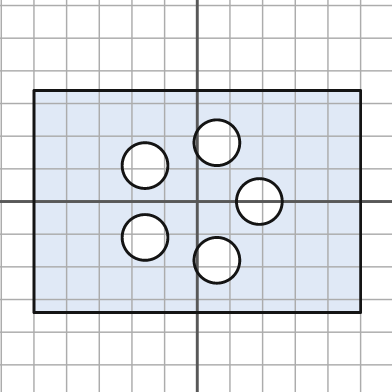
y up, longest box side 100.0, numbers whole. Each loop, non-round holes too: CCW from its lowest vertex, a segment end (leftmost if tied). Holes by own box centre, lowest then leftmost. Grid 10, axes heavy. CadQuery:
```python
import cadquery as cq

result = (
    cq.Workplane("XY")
    .moveTo(-50.0, -34.0)
    .lineTo(50.0, -34.0)
    .lineTo(50.0, 34.0)
    .lineTo(-50.0, 34.0)
    .close()
    .moveTo(6.0, -18.0)
    .circle(7.0)
    .moveTo(-16.0, -11.0)
    .circle(7.0)
    .moveTo(19.0, 0.0)
    .circle(7.0)
    .moveTo(-16.0, 11.0)
    .circle(7.0)
    .moveTo(6.0, 18.0)
    .circle(7.0)
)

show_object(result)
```